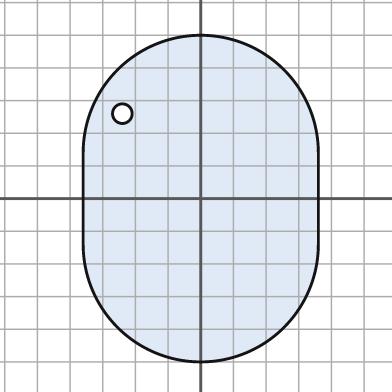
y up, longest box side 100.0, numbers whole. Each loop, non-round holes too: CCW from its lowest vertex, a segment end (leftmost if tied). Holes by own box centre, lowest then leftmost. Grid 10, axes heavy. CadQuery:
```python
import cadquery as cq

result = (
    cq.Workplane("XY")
    .moveTo(-36.0, -14.0)
    .threePointArc((0.0, -50.0), (36.0, -14.0))
    .lineTo(36.0, 14.0)
    .threePointArc((0.0, 50.0), (-36.0, 14.0))
    .close()
    .moveTo(-24.0, 26.0)
    .circle(3.0)
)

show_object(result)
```